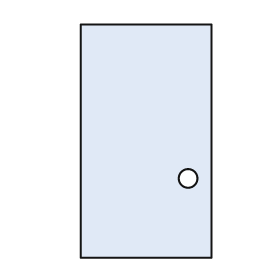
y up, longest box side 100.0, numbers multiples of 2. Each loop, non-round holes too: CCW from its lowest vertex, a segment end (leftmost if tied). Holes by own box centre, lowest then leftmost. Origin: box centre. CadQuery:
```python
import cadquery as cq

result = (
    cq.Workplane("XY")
    .moveTo(-28.0, -50.0)
    .lineTo(28.0, -50.0)
    .lineTo(28.0, 50.0)
    .lineTo(-28.0, 50.0)
    .close()
    .moveTo(18.0, -16.0)
    .circle(4.0)
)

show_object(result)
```